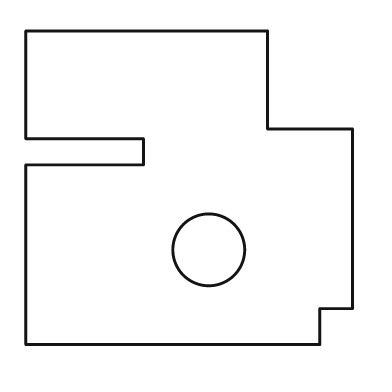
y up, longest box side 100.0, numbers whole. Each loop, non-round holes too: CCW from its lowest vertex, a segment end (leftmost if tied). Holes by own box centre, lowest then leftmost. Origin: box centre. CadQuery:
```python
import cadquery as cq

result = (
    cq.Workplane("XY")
    .moveTo(-50.0, -48.0)
    .lineTo(40.0, -48.0)
    .lineTo(40.0, -37.0)
    .lineTo(50.0, -37.0)
    .lineTo(50.0, 18.0)
    .lineTo(24.0, 18.0)
    .lineTo(24.0, 48.0)
    .lineTo(-50.0, 48.0)
    .lineTo(-50.0, 15.0)
    .lineTo(-14.0, 15.0)
    .lineTo(-14.0, 7.0)
    .lineTo(-50.0, 7.0)
    .close()
    .moveTo(6.0, -19.0)
    .circle(11.0)
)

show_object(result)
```